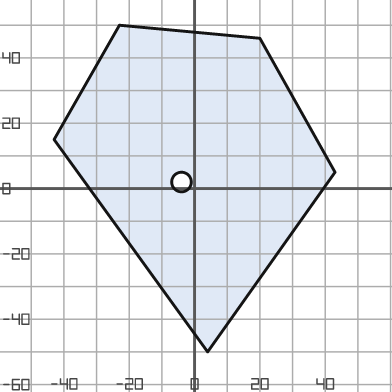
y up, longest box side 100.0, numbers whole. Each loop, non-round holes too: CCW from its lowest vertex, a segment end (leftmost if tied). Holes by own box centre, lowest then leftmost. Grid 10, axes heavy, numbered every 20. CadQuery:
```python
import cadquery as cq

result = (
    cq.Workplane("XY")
    .moveTo(4.0, -50.0)
    .lineTo(43.0, 5.0)
    .lineTo(20.0, 46.0)
    .lineTo(-23.0, 50.0)
    .lineTo(-43.0, 15.0)
    .close()
    .moveTo(-4.0, 2.0)
    .circle(3.0)
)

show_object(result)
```